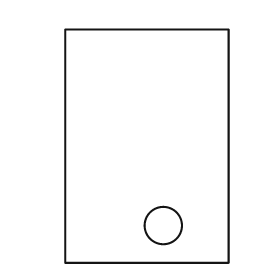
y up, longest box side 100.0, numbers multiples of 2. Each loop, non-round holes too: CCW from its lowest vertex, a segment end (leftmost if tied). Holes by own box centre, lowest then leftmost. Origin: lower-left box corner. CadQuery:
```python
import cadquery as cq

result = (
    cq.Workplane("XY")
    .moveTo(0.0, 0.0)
    .lineTo(70.0, 0.0)
    .lineTo(70.0, 100.0)
    .lineTo(0.0, 100.0)
    .close()
    .moveTo(42.0, 16.0)
    .circle(8.0)
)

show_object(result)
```